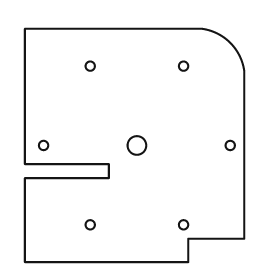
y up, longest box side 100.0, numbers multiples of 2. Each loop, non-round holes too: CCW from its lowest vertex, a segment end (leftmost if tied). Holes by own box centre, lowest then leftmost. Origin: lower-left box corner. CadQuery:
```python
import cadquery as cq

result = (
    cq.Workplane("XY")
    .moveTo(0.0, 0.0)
    .lineTo(70.0, 0.0)
    .lineTo(70.0, 10.0)
    .lineTo(94.0, 10.0)
    .lineTo(94.0, 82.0)
    .threePointArc((88.0, 94.0), (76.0, 100.0))
    .lineTo(0.0, 100.0)
    .lineTo(0.0, 42.0)
    .lineTo(36.0, 42.0)
    .lineTo(36.0, 36.0)
    .lineTo(0.0, 36.0)
    .close()
    .moveTo(28.0, 16.0)
    .circle(2.0)
    .moveTo(68.0, 16.0)
    .circle(2.0)
    .moveTo(8.0, 50.0)
    .circle(2.0)
    .moveTo(48.0, 50.0)
    .circle(4.0)
    .moveTo(88.0, 50.0)
    .circle(2.0)
    .moveTo(28.0, 84.0)
    .circle(2.0)
    .moveTo(68.0, 84.0)
    .circle(2.0)
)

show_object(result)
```